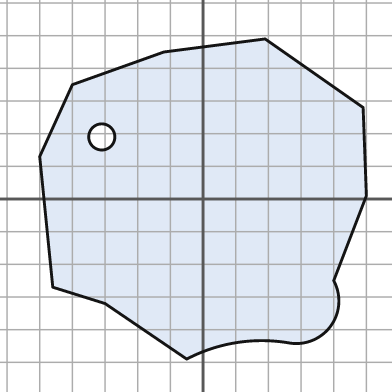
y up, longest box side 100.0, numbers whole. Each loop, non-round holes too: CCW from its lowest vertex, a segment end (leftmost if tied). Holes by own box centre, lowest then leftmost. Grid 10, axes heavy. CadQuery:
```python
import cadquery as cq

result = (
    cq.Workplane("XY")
    .moveTo(-5.0, -49.0)
    .threePointArc((10.0, -44.0), (26.0, -44.0))
    .threePointArc((39.0, -39.0), (40.0, -25.0))
    .lineTo(50.0, 1.0)
    .lineTo(49.0, 28.0)
    .lineTo(19.0, 49.0)
    .lineTo(-12.0, 45.0)
    .lineTo(-40.0, 35.0)
    .lineTo(-50.0, 13.0)
    .lineTo(-46.0, -27.0)
    .lineTo(-30.0, -32.0)
    .close()
    .moveTo(-31.0, 19.0)
    .circle(4.0)
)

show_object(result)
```